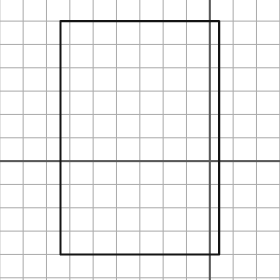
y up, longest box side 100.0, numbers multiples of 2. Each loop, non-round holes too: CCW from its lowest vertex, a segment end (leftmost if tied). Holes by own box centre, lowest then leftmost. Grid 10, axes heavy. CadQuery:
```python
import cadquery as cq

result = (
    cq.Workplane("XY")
    .moveTo(-64.0, -40.0)
    .lineTo(4.0, -40.0)
    .lineTo(4.0, 60.0)
    .lineTo(-64.0, 60.0)
    .close()
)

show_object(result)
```